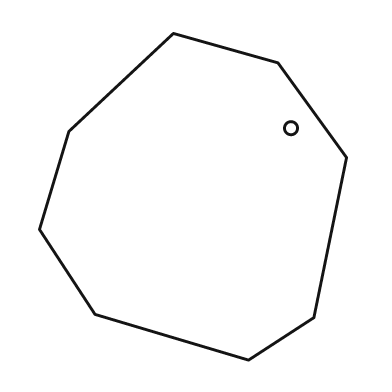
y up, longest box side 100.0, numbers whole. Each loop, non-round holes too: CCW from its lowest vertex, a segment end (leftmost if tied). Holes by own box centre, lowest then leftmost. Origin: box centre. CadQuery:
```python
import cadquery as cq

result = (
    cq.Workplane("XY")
    .moveTo(17.0, -50.0)
    .lineTo(37.0, -37.0)
    .lineTo(47.0, 12.0)
    .lineTo(26.0, 41.0)
    .lineTo(-6.0, 50.0)
    .lineTo(-38.0, 20.0)
    .lineTo(-47.0, -10.0)
    .lineTo(-30.0, -36.0)
    .close()
    .moveTo(30.0, 21.0)
    .circle(2.0)
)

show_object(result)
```